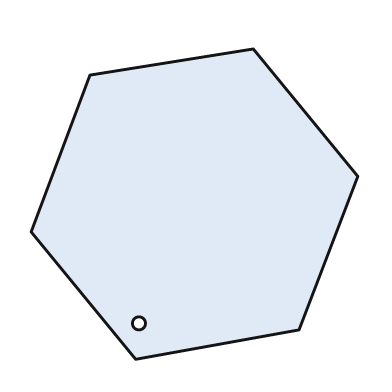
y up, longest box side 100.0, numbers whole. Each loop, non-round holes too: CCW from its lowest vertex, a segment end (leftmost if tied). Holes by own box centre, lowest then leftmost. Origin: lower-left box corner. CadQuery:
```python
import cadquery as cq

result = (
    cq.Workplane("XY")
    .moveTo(32.0, 0.0)
    .lineTo(82.0, 9.0)
    .lineTo(100.0, 56.0)
    .lineTo(68.0, 95.0)
    .lineTo(18.0, 87.0)
    .lineTo(0.0, 39.0)
    .close()
    .moveTo(33.0, 11.0)
    .circle(2.0)
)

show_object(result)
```